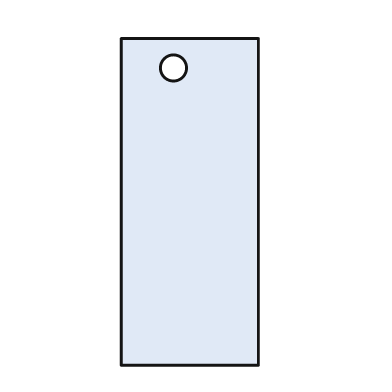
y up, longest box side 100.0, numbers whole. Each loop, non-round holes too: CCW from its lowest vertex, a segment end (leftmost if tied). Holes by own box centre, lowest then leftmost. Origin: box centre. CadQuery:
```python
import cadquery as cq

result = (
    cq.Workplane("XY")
    .moveTo(-21.0, -50.0)
    .lineTo(21.0, -50.0)
    .lineTo(21.0, 50.0)
    .lineTo(-21.0, 50.0)
    .close()
    .moveTo(-5.0, 41.0)
    .circle(4.0)
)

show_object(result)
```